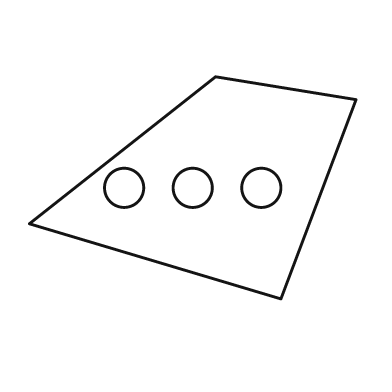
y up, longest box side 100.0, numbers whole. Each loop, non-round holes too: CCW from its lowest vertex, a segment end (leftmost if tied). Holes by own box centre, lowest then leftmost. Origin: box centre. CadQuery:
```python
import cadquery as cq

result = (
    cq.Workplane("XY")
    .moveTo(27.0, -34.0)
    .lineTo(50.0, 27.0)
    .lineTo(7.0, 34.0)
    .lineTo(-50.0, -11.0)
    .close()
    .moveTo(-21.0, 0.0)
    .circle(6.0)
    .moveTo(0.0, 0.0)
    .circle(6.0)
    .moveTo(21.0, 0.0)
    .circle(6.0)
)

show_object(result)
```